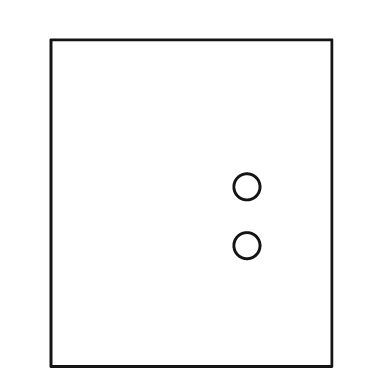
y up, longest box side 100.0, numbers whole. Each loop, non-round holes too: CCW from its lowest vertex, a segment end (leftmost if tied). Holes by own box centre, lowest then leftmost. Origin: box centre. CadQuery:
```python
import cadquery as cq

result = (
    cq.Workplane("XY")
    .moveTo(-43.0, -50.0)
    .lineTo(43.0, -50.0)
    .lineTo(43.0, 50.0)
    .lineTo(-43.0, 50.0)
    .close()
    .moveTo(17.0, -13.0)
    .circle(4.0)
    .moveTo(17.0, 5.0)
    .circle(4.0)
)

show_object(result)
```